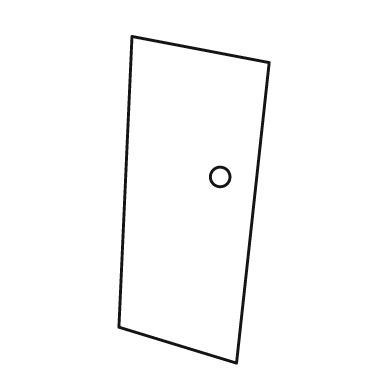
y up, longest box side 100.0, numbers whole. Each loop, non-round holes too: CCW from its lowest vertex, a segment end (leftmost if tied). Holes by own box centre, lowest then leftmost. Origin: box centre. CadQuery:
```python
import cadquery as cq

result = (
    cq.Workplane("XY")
    .moveTo(13.0, -50.0)
    .lineTo(23.0, 42.0)
    .lineTo(-19.0, 50.0)
    .lineTo(-23.0, -39.0)
    .close()
    .moveTo(8.0, 7.0)
    .circle(3.0)
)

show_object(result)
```